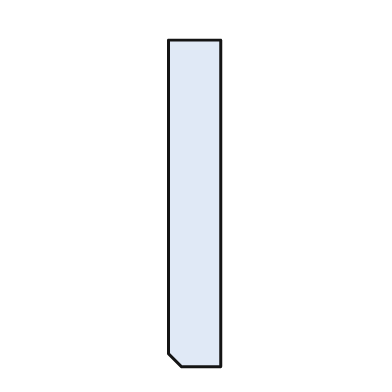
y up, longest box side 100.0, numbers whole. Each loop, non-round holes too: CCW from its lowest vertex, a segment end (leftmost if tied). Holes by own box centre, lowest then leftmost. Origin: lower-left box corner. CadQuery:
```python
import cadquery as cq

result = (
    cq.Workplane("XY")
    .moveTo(4.0, 0.0)
    .lineTo(16.0, 0.0)
    .lineTo(16.0, 100.0)
    .lineTo(0.0, 100.0)
    .lineTo(0.0, 4.0)
    .close()
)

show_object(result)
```